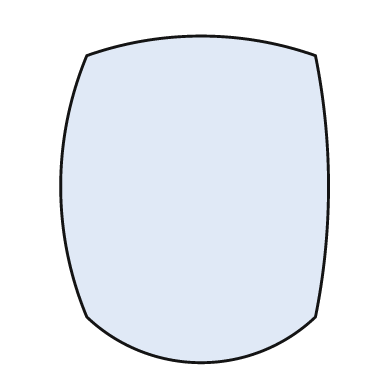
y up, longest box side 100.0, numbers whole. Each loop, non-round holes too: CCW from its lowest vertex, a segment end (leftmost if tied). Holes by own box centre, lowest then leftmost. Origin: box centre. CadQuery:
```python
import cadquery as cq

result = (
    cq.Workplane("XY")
    .moveTo(-33.0, -36.0)
    .threePointArc((2.0, -50.0), (37.0, -36.0))
    .threePointArc((41.0, 4.0), (37.0, 44.0))
    .threePointArc((2.0, 50.0), (-33.0, 44.0))
    .threePointArc((-41.0, 4.0), (-33.0, -36.0))
    .close()
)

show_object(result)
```